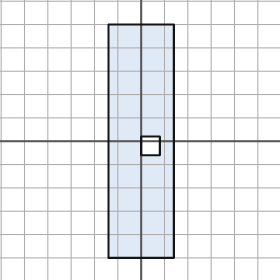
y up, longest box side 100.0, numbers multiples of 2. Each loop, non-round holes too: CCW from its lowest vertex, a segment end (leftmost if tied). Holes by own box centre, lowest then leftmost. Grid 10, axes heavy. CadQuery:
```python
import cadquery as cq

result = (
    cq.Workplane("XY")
    .moveTo(-14.0, -50.0)
    .lineTo(14.0, -50.0)
    .lineTo(14.0, 50.0)
    .lineTo(-14.0, 50.0)
    .close()
    .moveTo(0.0, -6.0)
    .lineTo(8.0, -6.0)
    .lineTo(8.0, 2.0)
    .lineTo(0.0, 2.0)
    .close()
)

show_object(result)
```